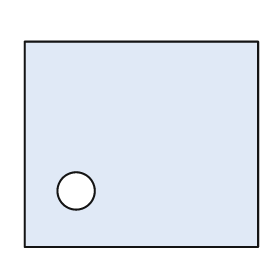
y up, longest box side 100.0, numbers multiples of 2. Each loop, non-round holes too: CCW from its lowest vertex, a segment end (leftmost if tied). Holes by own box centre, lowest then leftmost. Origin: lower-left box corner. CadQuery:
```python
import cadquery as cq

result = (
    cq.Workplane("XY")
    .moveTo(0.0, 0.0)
    .lineTo(100.0, 0.0)
    .lineTo(100.0, 88.0)
    .lineTo(0.0, 88.0)
    .close()
    .moveTo(22.0, 24.0)
    .circle(8.0)
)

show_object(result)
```